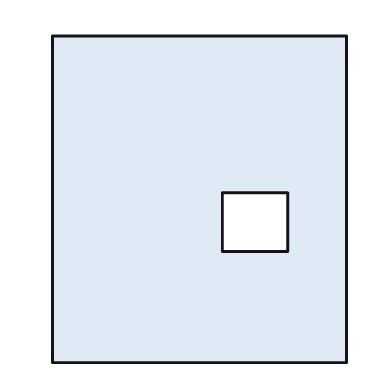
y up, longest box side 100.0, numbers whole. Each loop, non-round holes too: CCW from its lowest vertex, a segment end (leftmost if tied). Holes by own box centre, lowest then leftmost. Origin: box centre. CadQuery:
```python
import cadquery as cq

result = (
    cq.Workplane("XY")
    .moveTo(-45.0, -50.0)
    .lineTo(45.0, -50.0)
    .lineTo(45.0, 50.0)
    .lineTo(-45.0, 50.0)
    .close()
    .moveTo(7.0, -16.0)
    .lineTo(27.0, -16.0)
    .lineTo(27.0, 2.0)
    .lineTo(7.0, 2.0)
    .close()
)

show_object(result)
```